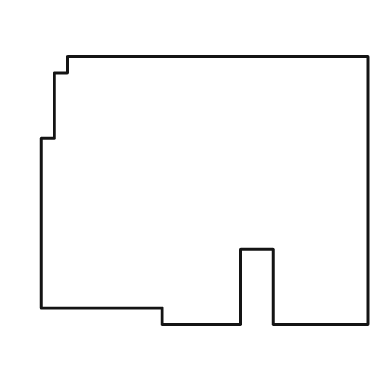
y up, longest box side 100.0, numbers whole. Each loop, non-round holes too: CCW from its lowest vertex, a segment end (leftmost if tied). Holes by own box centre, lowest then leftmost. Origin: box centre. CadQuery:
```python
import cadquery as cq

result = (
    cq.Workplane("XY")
    .moveTo(-13.0, -41.0)
    .lineTo(11.0, -41.0)
    .lineTo(11.0, -18.0)
    .lineTo(21.0, -18.0)
    .lineTo(21.0, -41.0)
    .lineTo(50.0, -41.0)
    .lineTo(50.0, 41.0)
    .lineTo(-42.0, 41.0)
    .lineTo(-42.0, 36.0)
    .lineTo(-46.0, 36.0)
    .lineTo(-46.0, 16.0)
    .lineTo(-50.0, 16.0)
    .lineTo(-50.0, -36.0)
    .lineTo(-13.0, -36.0)
    .close()
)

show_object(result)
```